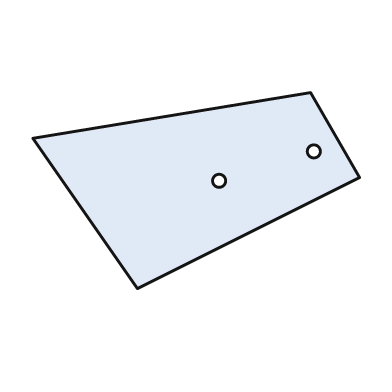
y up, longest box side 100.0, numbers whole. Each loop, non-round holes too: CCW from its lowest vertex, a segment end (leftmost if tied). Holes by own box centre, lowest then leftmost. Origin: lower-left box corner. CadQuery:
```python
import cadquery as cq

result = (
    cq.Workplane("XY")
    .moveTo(32.0, 0.0)
    .lineTo(100.0, 34.0)
    .lineTo(85.0, 60.0)
    .lineTo(0.0, 46.0)
    .close()
    .moveTo(57.0, 33.0)
    .circle(2.0)
    .moveTo(86.0, 42.0)
    .circle(2.0)
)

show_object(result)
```